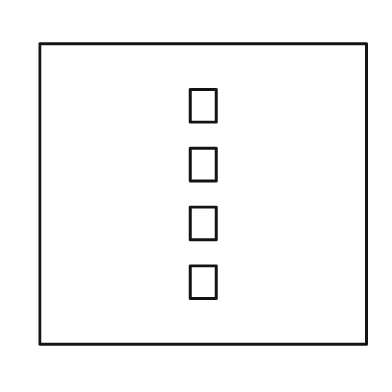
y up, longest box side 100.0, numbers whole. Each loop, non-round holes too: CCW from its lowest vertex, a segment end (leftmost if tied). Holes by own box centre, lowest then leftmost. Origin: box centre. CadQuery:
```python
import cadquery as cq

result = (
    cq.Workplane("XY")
    .moveTo(-50.0, -46.0)
    .lineTo(50.0, -46.0)
    .lineTo(50.0, 46.0)
    .lineTo(-50.0, 46.0)
    .close()
    .moveTo(-4.0, -32.0)
    .lineTo(4.0, -32.0)
    .lineTo(4.0, -22.0)
    .lineTo(-4.0, -22.0)
    .close()
    .moveTo(-4.0, -14.0)
    .lineTo(4.0, -14.0)
    .lineTo(4.0, -4.0)
    .lineTo(-4.0, -4.0)
    .close()
    .moveTo(-4.0, 4.0)
    .lineTo(4.0, 4.0)
    .lineTo(4.0, 14.0)
    .lineTo(-4.0, 14.0)
    .close()
    .moveTo(-4.0, 22.0)
    .lineTo(4.0, 22.0)
    .lineTo(4.0, 32.0)
    .lineTo(-4.0, 32.0)
    .close()
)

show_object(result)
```